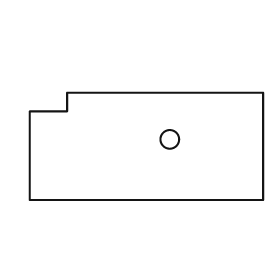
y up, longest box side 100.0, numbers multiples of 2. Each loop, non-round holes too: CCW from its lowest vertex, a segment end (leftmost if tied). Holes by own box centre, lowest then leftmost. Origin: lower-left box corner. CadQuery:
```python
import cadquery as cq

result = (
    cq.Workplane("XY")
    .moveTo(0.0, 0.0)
    .lineTo(100.0, 0.0)
    .lineTo(100.0, 46.0)
    .lineTo(16.0, 46.0)
    .lineTo(16.0, 38.0)
    .lineTo(0.0, 38.0)
    .close()
    .moveTo(60.0, 26.0)
    .circle(4.0)
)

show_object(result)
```